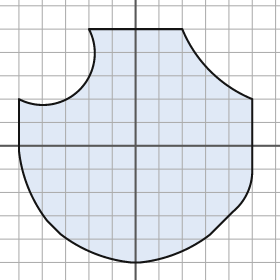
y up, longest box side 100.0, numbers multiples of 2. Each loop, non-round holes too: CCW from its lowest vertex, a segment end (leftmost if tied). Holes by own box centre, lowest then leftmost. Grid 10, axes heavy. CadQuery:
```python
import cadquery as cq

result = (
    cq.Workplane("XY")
    .moveTo(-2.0, -50.0)
    .lineTo(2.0, -50.0)
    .threePointArc((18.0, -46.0), (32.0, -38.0))
    .lineTo(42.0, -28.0)
    .threePointArc((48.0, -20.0), (50.0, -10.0))
    .lineTo(50.0, 20.0)
    .threePointArc((32.0, 32.0), (20.0, 50.0))
    .lineTo(-20.0, 50.0)
    .threePointArc((-24.0, 24.0), (-50.0, 20.0))
    .lineTo(-50.0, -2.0)
    .threePointArc((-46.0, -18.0), (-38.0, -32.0))
    .lineTo(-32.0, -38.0)
    .threePointArc((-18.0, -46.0), (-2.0, -50.0))
    .close()
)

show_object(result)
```